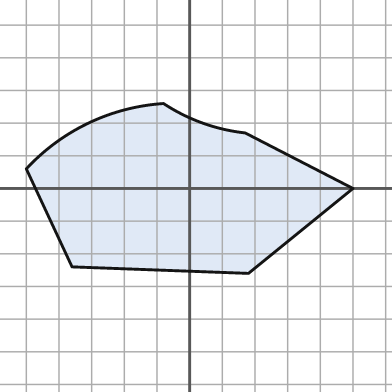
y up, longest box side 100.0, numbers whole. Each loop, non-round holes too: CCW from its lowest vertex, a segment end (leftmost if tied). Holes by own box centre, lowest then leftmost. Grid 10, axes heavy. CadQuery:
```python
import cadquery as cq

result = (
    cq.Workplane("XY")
    .moveTo(18.0, -26.0)
    .lineTo(50.0, 0.0)
    .lineTo(17.0, 17.0)
    .threePointArc((4.0, 20.0), (-8.0, 26.0))
    .threePointArc((-31.0, 20.0), (-50.0, 6.0))
    .lineTo(-36.0, -24.0)
    .close()
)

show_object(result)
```